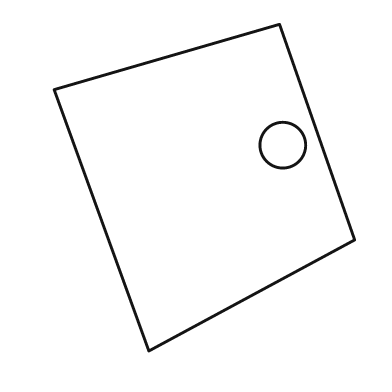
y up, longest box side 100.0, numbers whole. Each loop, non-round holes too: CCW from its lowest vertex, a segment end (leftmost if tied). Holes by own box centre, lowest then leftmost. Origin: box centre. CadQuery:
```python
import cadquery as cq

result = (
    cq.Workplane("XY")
    .moveTo(-17.0, -50.0)
    .lineTo(46.0, -16.0)
    .lineTo(23.0, 50.0)
    .lineTo(-46.0, 30.0)
    .close()
    .moveTo(24.0, 13.0)
    .circle(7.0)
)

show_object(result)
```